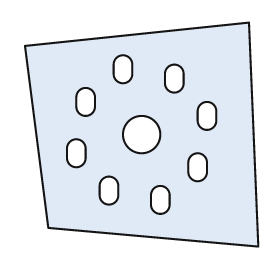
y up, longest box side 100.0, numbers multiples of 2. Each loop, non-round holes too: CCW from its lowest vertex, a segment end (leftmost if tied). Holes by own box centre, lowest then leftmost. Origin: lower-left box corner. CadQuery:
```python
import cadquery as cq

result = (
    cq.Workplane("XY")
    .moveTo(100.0, 0.0)
    .lineTo(96.0, 96.0)
    .lineTo(0.0, 86.0)
    .lineTo(10.0, 8.0)
    .close()
    .moveTo(54.0, 18.0)
    .threePointArc((58.0, 14.0), (62.0, 18.0))
    .lineTo(62.0, 22.0)
    .threePointArc((58.0, 26.0), (54.0, 22.0))
    .close()
    .moveTo(32.0, 22.0)
    .threePointArc((36.0, 18.0), (40.0, 22.0))
    .lineTo(40.0, 26.0)
    .threePointArc((36.0, 30.0), (32.0, 26.0))
    .close()
    .moveTo(70.0, 32.0)
    .threePointArc((74.0, 28.0), (78.0, 32.0))
    .lineTo(78.0, 36.0)
    .threePointArc((74.0, 40.0), (70.0, 36.0))
    .close()
    .moveTo(18.0, 38.0)
    .threePointArc((22.0, 34.0), (26.0, 38.0))
    .lineTo(26.0, 42.0)
    .threePointArc((22.0, 46.0), (18.0, 42.0))
    .close()
    .moveTo(50.0, 48.0)
    .circle(8.0)
    .moveTo(74.0, 54.0)
    .threePointArc((78.0, 50.0), (82.0, 54.0))
    .lineTo(82.0, 58.0)
    .threePointArc((78.0, 62.0), (74.0, 58.0))
    .close()
    .moveTo(22.0, 60.0)
    .threePointArc((26.0, 56.0), (30.0, 60.0))
    .lineTo(30.0, 64.0)
    .threePointArc((26.0, 68.0), (22.0, 64.0))
    .close()
    .moveTo(60.0, 70.0)
    .threePointArc((64.0, 66.0), (68.0, 70.0))
    .lineTo(68.0, 74.0)
    .threePointArc((64.0, 78.0), (60.0, 74.0))
    .close()
    .moveTo(38.0, 74.0)
    .threePointArc((42.0, 70.0), (46.0, 74.0))
    .lineTo(46.0, 78.0)
    .threePointArc((42.0, 82.0), (38.0, 78.0))
    .close()
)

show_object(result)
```